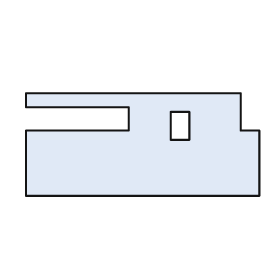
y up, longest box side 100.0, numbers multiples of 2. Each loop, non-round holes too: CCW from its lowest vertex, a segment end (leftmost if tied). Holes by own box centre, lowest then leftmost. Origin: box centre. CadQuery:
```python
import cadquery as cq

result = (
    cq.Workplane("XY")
    .moveTo(-50.0, -22.0)
    .lineTo(50.0, -22.0)
    .lineTo(50.0, 6.0)
    .lineTo(42.0, 6.0)
    .lineTo(42.0, 22.0)
    .lineTo(-50.0, 22.0)
    .lineTo(-50.0, 16.0)
    .lineTo(-6.0, 16.0)
    .lineTo(-6.0, 6.0)
    .lineTo(-50.0, 6.0)
    .close()
    .moveTo(12.0, 2.0)
    .lineTo(20.0, 2.0)
    .lineTo(20.0, 14.0)
    .lineTo(12.0, 14.0)
    .close()
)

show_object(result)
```